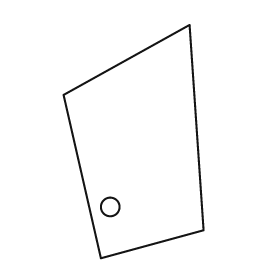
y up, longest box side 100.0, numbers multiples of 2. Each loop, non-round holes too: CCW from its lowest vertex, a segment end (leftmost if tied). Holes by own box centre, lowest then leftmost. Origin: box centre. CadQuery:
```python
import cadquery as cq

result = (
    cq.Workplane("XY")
    .moveTo(-14.0, -50.0)
    .lineTo(30.0, -38.0)
    .lineTo(24.0, 50.0)
    .lineTo(-30.0, 20.0)
    .close()
    .moveTo(-10.0, -28.0)
    .circle(4.0)
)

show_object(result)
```